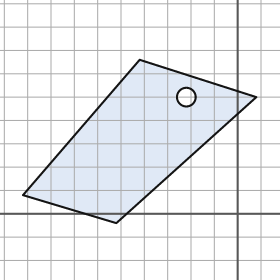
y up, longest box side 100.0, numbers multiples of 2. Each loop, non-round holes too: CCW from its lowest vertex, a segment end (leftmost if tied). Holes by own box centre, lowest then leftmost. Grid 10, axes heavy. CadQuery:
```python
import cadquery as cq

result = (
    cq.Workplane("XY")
    .moveTo(-52.0, -4.0)
    .lineTo(8.0, 50.0)
    .lineTo(-42.0, 66.0)
    .lineTo(-92.0, 8.0)
    .close()
    .moveTo(-22.0, 50.0)
    .circle(4.0)
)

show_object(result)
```